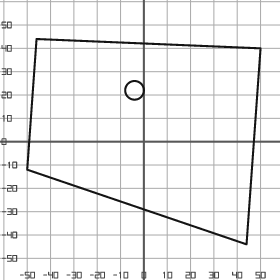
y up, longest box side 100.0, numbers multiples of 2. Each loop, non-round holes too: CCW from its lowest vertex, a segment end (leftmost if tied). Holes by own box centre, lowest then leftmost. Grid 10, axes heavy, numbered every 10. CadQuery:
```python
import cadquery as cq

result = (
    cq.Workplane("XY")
    .moveTo(44.0, -44.0)
    .lineTo(50.0, 40.0)
    .lineTo(-46.0, 44.0)
    .lineTo(-50.0, -12.0)
    .close()
    .moveTo(-4.0, 22.0)
    .circle(4.0)
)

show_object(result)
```